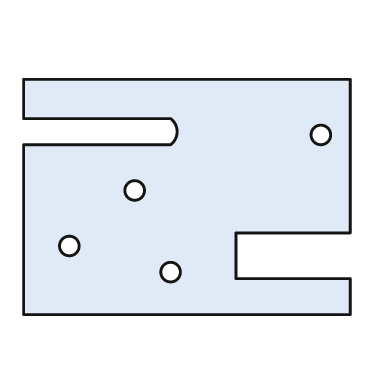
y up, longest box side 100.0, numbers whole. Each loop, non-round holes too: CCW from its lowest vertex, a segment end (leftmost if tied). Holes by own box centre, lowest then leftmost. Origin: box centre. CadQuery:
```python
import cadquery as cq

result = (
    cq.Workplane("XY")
    .moveTo(-50.0, -36.0)
    .lineTo(50.0, -36.0)
    .lineTo(50.0, -25.0)
    .lineTo(15.0, -25.0)
    .lineTo(15.0, -11.0)
    .lineTo(50.0, -11.0)
    .lineTo(50.0, 36.0)
    .lineTo(-50.0, 36.0)
    .lineTo(-50.0, 24.0)
    .lineTo(-5.0, 24.0)
    .threePointArc((-3.0, 20.0), (-5.0, 16.0))
    .lineTo(-50.0, 16.0)
    .close()
    .moveTo(-5.0, -23.0)
    .circle(3.0)
    .moveTo(-36.0, -15.0)
    .circle(3.0)
    .moveTo(-16.0, 2.0)
    .circle(3.0)
    .moveTo(41.0, 19.0)
    .circle(3.0)
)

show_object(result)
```